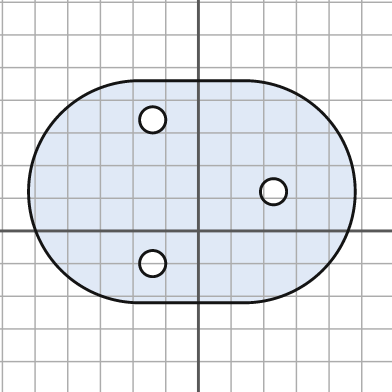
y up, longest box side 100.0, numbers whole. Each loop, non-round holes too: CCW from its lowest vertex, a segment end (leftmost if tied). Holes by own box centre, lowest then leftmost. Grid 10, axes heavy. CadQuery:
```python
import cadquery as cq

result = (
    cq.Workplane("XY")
    .moveTo(-18.0, -22.0)
    .lineTo(14.0, -22.0)
    .threePointArc((48.0, 12.0), (14.0, 46.0))
    .lineTo(-18.0, 46.0)
    .threePointArc((-52.0, 12.0), (-18.0, -22.0))
    .close()
    .moveTo(-14.0, -10.0)
    .circle(4.0)
    .moveTo(23.0, 12.0)
    .circle(4.0)
    .moveTo(-14.0, 34.0)
    .circle(4.0)
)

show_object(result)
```